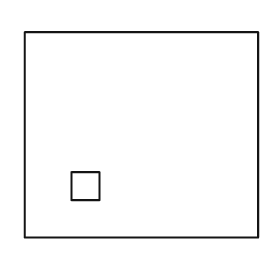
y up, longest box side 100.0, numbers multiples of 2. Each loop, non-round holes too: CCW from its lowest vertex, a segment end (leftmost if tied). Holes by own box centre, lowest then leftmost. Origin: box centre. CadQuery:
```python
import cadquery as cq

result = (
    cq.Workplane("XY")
    .moveTo(-50.0, -44.0)
    .lineTo(50.0, -44.0)
    .lineTo(50.0, 44.0)
    .lineTo(-50.0, 44.0)
    .close()
    .moveTo(-30.0, -28.0)
    .lineTo(-18.0, -28.0)
    .lineTo(-18.0, -16.0)
    .lineTo(-30.0, -16.0)
    .close()
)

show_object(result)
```